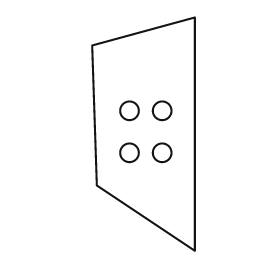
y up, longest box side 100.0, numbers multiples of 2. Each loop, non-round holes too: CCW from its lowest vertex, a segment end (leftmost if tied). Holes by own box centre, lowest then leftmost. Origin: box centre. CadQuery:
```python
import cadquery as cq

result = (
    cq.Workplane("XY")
    .moveTo(22.0, -50.0)
    .lineTo(22.0, 50.0)
    .lineTo(-22.0, 38.0)
    .lineTo(-20.0, -22.0)
    .close()
    .moveTo(-6.0, -8.0)
    .circle(4.0)
    .moveTo(8.0, -8.0)
    .circle(4.0)
    .moveTo(-6.0, 10.0)
    .circle(4.0)
    .moveTo(8.0, 10.0)
    .circle(4.0)
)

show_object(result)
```